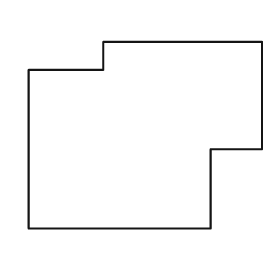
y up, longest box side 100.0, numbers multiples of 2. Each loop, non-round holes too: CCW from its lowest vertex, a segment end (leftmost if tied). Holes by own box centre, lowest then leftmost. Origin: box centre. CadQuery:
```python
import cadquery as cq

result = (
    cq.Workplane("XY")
    .moveTo(-50.0, -40.0)
    .lineTo(28.0, -40.0)
    .lineTo(28.0, -6.0)
    .lineTo(50.0, -6.0)
    .lineTo(50.0, 40.0)
    .lineTo(-18.0, 40.0)
    .lineTo(-18.0, 28.0)
    .lineTo(-50.0, 28.0)
    .close()
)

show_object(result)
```